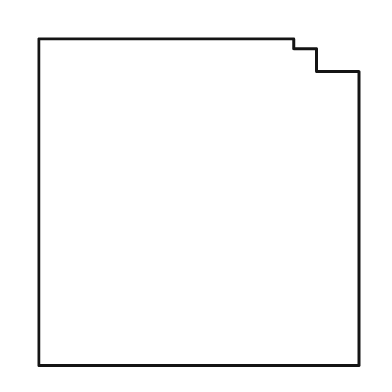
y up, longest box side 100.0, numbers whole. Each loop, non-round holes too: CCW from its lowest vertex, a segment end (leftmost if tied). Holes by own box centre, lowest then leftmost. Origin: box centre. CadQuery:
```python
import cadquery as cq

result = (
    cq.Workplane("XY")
    .moveTo(-49.0, -50.0)
    .lineTo(49.0, -50.0)
    .lineTo(49.0, 40.0)
    .lineTo(36.0, 40.0)
    .lineTo(36.0, 47.0)
    .lineTo(29.0, 47.0)
    .lineTo(29.0, 50.0)
    .lineTo(-49.0, 50.0)
    .close()
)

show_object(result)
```